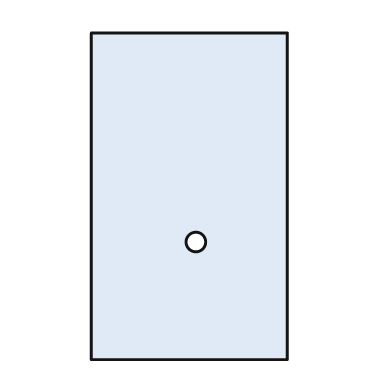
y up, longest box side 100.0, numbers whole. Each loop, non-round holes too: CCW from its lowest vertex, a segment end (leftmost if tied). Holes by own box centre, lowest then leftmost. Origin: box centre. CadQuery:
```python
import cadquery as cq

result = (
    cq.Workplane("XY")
    .moveTo(-30.0, -50.0)
    .lineTo(30.0, -50.0)
    .lineTo(30.0, 50.0)
    .lineTo(-30.0, 50.0)
    .close()
    .moveTo(2.0, -14.0)
    .circle(3.0)
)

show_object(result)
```